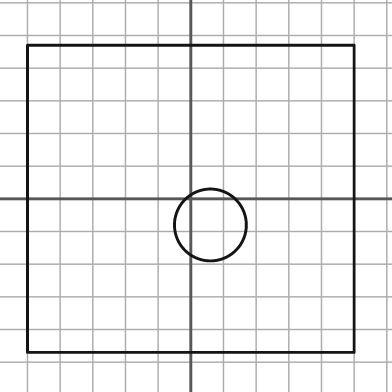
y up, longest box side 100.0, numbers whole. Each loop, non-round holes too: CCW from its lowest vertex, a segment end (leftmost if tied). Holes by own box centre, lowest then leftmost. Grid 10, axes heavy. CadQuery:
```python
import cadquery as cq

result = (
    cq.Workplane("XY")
    .moveTo(-50.0, -47.0)
    .lineTo(50.0, -47.0)
    .lineTo(50.0, 47.0)
    .lineTo(-50.0, 47.0)
    .close()
    .moveTo(6.0, -8.0)
    .circle(11.0)
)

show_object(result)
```